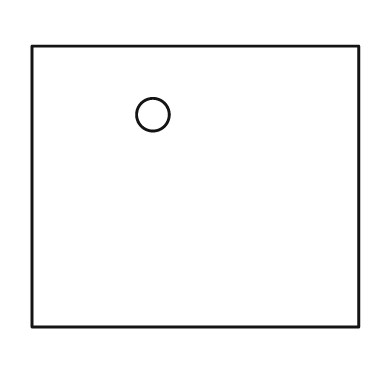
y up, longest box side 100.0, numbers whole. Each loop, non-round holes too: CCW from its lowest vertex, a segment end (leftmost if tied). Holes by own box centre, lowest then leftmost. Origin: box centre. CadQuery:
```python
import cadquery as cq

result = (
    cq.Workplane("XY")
    .moveTo(-50.0, -43.0)
    .lineTo(50.0, -43.0)
    .lineTo(50.0, 43.0)
    .lineTo(-50.0, 43.0)
    .close()
    .moveTo(-13.0, 22.0)
    .circle(5.0)
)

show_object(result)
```